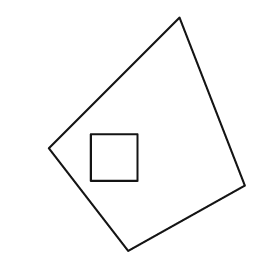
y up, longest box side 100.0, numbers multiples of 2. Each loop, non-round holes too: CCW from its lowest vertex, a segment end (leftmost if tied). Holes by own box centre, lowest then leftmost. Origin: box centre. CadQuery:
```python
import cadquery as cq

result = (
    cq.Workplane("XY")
    .moveTo(-8.0, -50.0)
    .lineTo(42.0, -22.0)
    .lineTo(14.0, 50.0)
    .lineTo(-42.0, -6.0)
    .close()
    .moveTo(-24.0, -20.0)
    .lineTo(-4.0, -20.0)
    .lineTo(-4.0, 0.0)
    .lineTo(-24.0, 0.0)
    .close()
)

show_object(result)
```